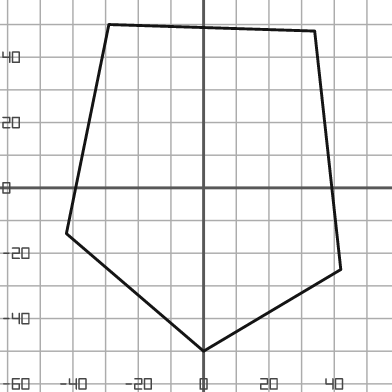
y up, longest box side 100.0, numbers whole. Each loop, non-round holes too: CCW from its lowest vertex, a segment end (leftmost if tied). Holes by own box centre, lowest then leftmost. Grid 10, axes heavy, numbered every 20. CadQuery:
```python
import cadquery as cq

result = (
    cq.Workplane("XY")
    .moveTo(0.0, -50.0)
    .lineTo(42.0, -25.0)
    .lineTo(34.0, 48.0)
    .lineTo(-29.0, 50.0)
    .lineTo(-42.0, -14.0)
    .close()
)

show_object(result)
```